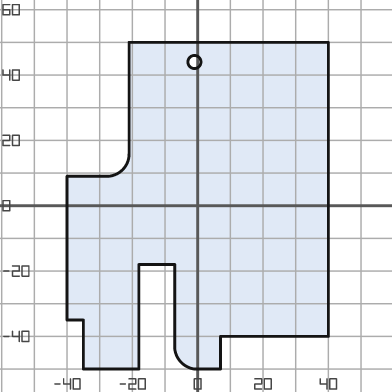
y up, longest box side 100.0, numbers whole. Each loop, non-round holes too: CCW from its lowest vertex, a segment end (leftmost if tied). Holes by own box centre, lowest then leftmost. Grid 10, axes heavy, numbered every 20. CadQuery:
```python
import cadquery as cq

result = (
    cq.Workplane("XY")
    .moveTo(-35.0, -50.0)
    .lineTo(-18.0, -50.0)
    .lineTo(-18.0, -18.0)
    .lineTo(-7.0, -18.0)
    .lineTo(-7.0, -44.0)
    .threePointArc((-5.0, -48.0), (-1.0, -50.0))
    .lineTo(7.0, -50.0)
    .lineTo(7.0, -40.0)
    .lineTo(40.0, -40.0)
    .lineTo(40.0, 50.0)
    .lineTo(-21.0, 50.0)
    .lineTo(-21.0, 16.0)
    .threePointArc((-23.0, 11.0), (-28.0, 9.0))
    .lineTo(-40.0, 9.0)
    .lineTo(-40.0, -35.0)
    .lineTo(-35.0, -35.0)
    .close()
    .moveTo(-1.0, 44.0)
    .circle(2.0)
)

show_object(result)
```